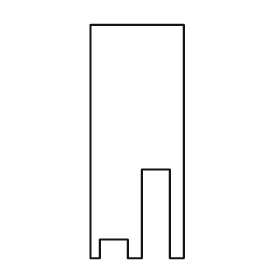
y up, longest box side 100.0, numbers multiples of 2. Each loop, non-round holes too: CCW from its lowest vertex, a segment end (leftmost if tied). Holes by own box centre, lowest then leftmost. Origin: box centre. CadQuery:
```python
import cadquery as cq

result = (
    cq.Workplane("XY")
    .moveTo(-20.0, -50.0)
    .lineTo(-16.0, -50.0)
    .lineTo(-16.0, -42.0)
    .lineTo(-4.0, -42.0)
    .lineTo(-4.0, -50.0)
    .lineTo(2.0, -50.0)
    .lineTo(2.0, -12.0)
    .lineTo(14.0, -12.0)
    .lineTo(14.0, -50.0)
    .lineTo(20.0, -50.0)
    .lineTo(20.0, 50.0)
    .lineTo(-20.0, 50.0)
    .close()
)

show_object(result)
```